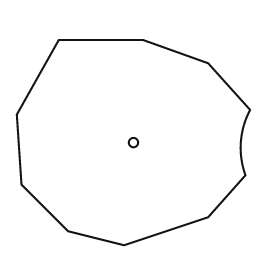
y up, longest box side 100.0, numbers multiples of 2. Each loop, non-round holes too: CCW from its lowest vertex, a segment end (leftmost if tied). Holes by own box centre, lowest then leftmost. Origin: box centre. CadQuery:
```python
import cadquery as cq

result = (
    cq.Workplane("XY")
    .moveTo(-4.0, -44.0)
    .lineTo(32.0, -32.0)
    .lineTo(48.0, -14.0)
    .threePointArc((46.0, 0.0), (50.0, 14.0))
    .lineTo(32.0, 34.0)
    .lineTo(4.0, 44.0)
    .lineTo(-32.0, 44.0)
    .lineTo(-50.0, 12.0)
    .lineTo(-48.0, -18.0)
    .lineTo(-28.0, -38.0)
    .close()
    .moveTo(0.0, 0.0)
    .circle(2.0)
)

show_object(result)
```